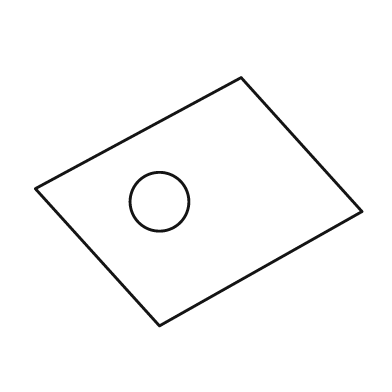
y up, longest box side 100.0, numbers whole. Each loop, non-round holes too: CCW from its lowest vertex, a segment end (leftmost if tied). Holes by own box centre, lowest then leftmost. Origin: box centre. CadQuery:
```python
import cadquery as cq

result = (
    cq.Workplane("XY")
    .moveTo(-12.0, -38.0)
    .lineTo(50.0, -3.0)
    .lineTo(13.0, 38.0)
    .lineTo(-50.0, 4.0)
    .close()
    .moveTo(-12.0, 0.0)
    .circle(9.0)
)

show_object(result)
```